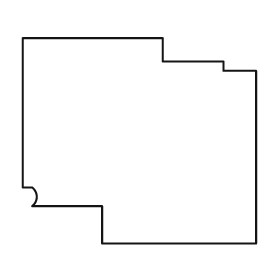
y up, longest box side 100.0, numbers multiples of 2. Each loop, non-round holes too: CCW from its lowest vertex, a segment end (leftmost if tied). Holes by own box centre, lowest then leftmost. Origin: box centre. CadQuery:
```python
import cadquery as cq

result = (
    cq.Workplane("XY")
    .moveTo(-16.0, -44.0)
    .lineTo(50.0, -44.0)
    .lineTo(50.0, 30.0)
    .lineTo(36.0, 30.0)
    .lineTo(36.0, 34.0)
    .lineTo(10.0, 34.0)
    .lineTo(10.0, 44.0)
    .lineTo(-50.0, 44.0)
    .lineTo(-50.0, -20.0)
    .lineTo(-46.0, -20.0)
    .threePointArc((-44.0, -24.0), (-46.0, -28.0))
    .lineTo(-16.0, -28.0)
    .close()
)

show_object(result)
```